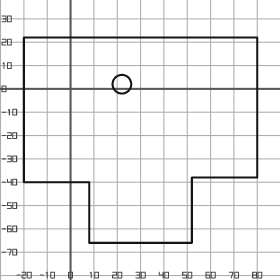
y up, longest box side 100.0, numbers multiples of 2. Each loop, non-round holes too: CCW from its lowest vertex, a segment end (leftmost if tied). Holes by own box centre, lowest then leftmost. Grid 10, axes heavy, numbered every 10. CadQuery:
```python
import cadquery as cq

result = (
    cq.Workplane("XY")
    .moveTo(8.0, -66.0)
    .lineTo(52.0, -66.0)
    .lineTo(52.0, -38.0)
    .lineTo(80.0, -38.0)
    .lineTo(80.0, 22.0)
    .lineTo(-20.0, 22.0)
    .lineTo(-20.0, -40.0)
    .lineTo(8.0, -40.0)
    .close()
    .moveTo(22.0, 2.0)
    .circle(4.0)
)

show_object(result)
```